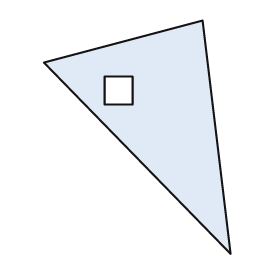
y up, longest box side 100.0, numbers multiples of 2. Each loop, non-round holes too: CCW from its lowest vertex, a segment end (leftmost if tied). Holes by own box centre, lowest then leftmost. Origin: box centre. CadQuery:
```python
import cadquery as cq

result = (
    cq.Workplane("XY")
    .moveTo(40.0, -50.0)
    .lineTo(28.0, 50.0)
    .lineTo(-40.0, 32.0)
    .close()
    .moveTo(-14.0, 14.0)
    .lineTo(-2.0, 14.0)
    .lineTo(-2.0, 26.0)
    .lineTo(-14.0, 26.0)
    .close()
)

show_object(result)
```